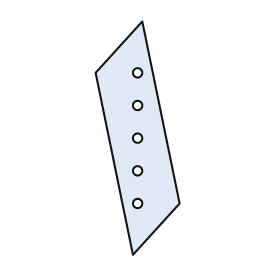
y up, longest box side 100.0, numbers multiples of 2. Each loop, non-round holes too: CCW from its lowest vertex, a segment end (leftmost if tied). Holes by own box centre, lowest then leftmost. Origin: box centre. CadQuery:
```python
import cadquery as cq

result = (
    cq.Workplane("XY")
    .moveTo(-2.0, -50.0)
    .lineTo(18.0, -28.0)
    .lineTo(2.0, 50.0)
    .lineTo(-18.0, 28.0)
    .close()
    .moveTo(0.0, -28.0)
    .circle(2.0)
    .moveTo(0.0, -14.0)
    .circle(2.0)
    .moveTo(0.0, 0.0)
    .circle(2.0)
    .moveTo(0.0, 14.0)
    .circle(2.0)
    .moveTo(0.0, 28.0)
    .circle(2.0)
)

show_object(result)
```